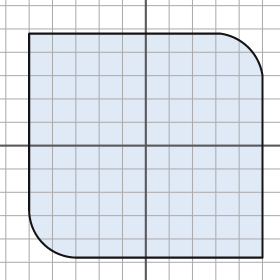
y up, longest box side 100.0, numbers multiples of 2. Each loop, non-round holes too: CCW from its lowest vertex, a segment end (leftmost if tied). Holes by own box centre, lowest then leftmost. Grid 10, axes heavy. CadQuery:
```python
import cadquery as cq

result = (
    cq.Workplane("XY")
    .moveTo(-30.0, -48.0)
    .lineTo(50.0, -48.0)
    .lineTo(50.0, 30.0)
    .threePointArc((44.0, 42.0), (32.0, 48.0))
    .lineTo(-50.0, 48.0)
    .lineTo(-50.0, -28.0)
    .threePointArc((-44.0, -42.0), (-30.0, -48.0))
    .close()
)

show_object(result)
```